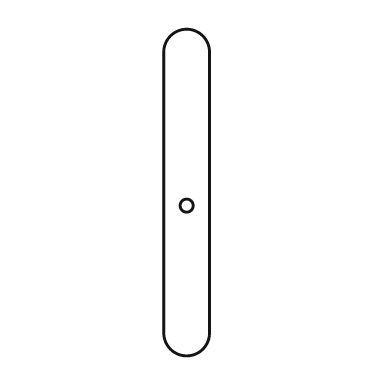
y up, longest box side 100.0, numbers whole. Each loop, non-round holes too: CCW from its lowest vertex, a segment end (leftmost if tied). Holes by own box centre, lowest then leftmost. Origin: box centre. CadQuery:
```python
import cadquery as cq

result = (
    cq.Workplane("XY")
    .moveTo(-7.0, -43.0)
    .threePointArc((0.0, -50.0), (7.0, -43.0))
    .lineTo(7.0, 43.0)
    .threePointArc((0.0, 50.0), (-7.0, 43.0))
    .close()
    .moveTo(0.0, -4.0)
    .circle(2.0)
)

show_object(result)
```